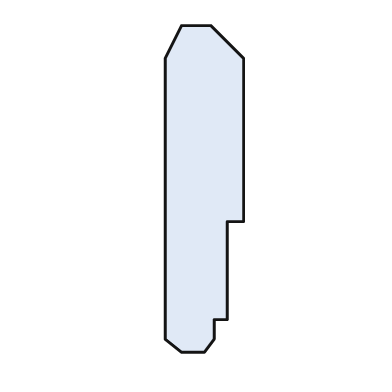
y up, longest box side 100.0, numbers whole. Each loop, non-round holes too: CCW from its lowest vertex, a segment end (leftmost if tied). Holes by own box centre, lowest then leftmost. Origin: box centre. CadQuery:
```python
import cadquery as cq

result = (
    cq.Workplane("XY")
    .moveTo(-7.0, -50.0)
    .lineTo(0.0, -50.0)
    .lineTo(3.0, -46.0)
    .lineTo(3.0, -40.0)
    .lineTo(7.0, -40.0)
    .lineTo(7.0, -10.0)
    .lineTo(12.0, -10.0)
    .lineTo(12.0, 40.0)
    .lineTo(2.0, 50.0)
    .lineTo(-7.0, 50.0)
    .lineTo(-12.0, 40.0)
    .lineTo(-12.0, -46.0)
    .close()
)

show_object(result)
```